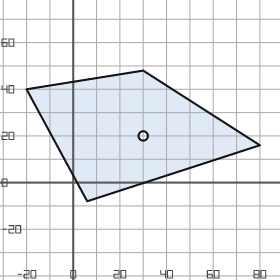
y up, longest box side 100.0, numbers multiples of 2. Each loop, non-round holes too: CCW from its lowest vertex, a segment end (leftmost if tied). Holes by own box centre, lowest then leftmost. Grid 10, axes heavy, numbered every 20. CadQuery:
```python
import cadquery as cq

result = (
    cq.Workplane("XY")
    .moveTo(6.0, -8.0)
    .lineTo(80.0, 16.0)
    .lineTo(30.0, 48.0)
    .lineTo(-20.0, 40.0)
    .close()
    .moveTo(30.0, 20.0)
    .circle(2.0)
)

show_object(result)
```